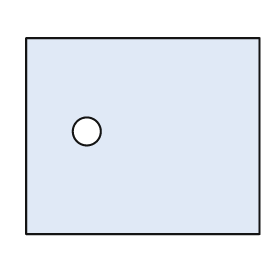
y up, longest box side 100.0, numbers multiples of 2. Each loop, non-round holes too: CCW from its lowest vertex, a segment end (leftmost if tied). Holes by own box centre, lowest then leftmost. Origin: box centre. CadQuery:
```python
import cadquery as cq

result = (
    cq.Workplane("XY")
    .moveTo(-50.0, -42.0)
    .lineTo(50.0, -42.0)
    .lineTo(50.0, 42.0)
    .lineTo(-50.0, 42.0)
    .close()
    .moveTo(-24.0, 2.0)
    .circle(6.0)
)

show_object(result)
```